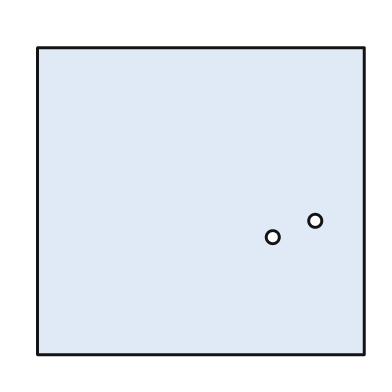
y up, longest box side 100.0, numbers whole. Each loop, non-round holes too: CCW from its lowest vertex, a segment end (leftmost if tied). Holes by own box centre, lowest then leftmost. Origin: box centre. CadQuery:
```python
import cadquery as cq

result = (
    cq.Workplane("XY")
    .moveTo(-50.0, -47.0)
    .lineTo(50.0, -47.0)
    .lineTo(50.0, 47.0)
    .lineTo(-50.0, 47.0)
    .close()
    .moveTo(22.0, -11.0)
    .circle(2.0)
    .moveTo(35.0, -6.0)
    .circle(2.0)
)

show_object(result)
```